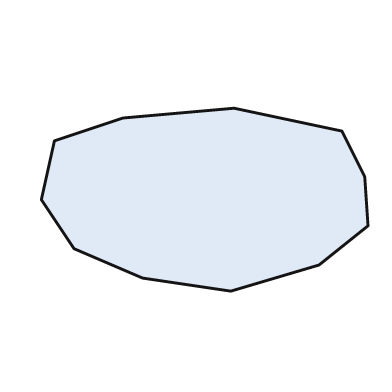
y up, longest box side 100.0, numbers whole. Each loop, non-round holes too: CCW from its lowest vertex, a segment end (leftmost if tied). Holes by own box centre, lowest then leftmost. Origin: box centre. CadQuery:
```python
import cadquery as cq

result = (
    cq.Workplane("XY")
    .moveTo(8.0, -28.0)
    .lineTo(35.0, -20.0)
    .lineTo(50.0, -8.0)
    .lineTo(49.0, 7.0)
    .lineTo(42.0, 21.0)
    .lineTo(9.0, 28.0)
    .lineTo(-25.0, 25.0)
    .lineTo(-46.0, 18.0)
    .lineTo(-50.0, 0.0)
    .lineTo(-40.0, -15.0)
    .lineTo(-19.0, -24.0)
    .close()
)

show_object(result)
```